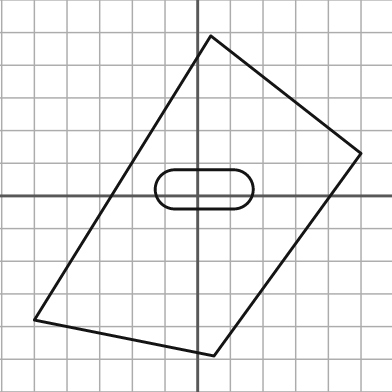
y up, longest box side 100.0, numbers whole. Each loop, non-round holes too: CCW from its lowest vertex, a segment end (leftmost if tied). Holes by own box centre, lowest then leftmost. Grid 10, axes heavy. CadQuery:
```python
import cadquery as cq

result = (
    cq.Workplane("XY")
    .moveTo(5.0, -49.0)
    .lineTo(50.0, 13.0)
    .lineTo(4.0, 49.0)
    .lineTo(-50.0, -38.0)
    .close()
    .moveTo(-7.0, -4.0)
    .lineTo(11.0, -4.0)
    .threePointArc((17.0, 2.0), (11.0, 8.0))
    .lineTo(-7.0, 8.0)
    .threePointArc((-13.0, 2.0), (-7.0, -4.0))
    .close()
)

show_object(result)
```